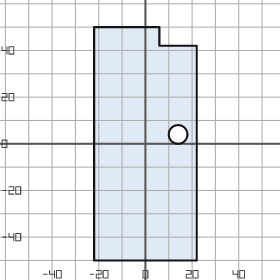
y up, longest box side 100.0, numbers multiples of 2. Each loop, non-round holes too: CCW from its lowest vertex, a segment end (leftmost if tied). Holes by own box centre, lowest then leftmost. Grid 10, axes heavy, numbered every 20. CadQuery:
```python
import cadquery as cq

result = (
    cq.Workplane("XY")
    .moveTo(-22.0, -50.0)
    .lineTo(22.0, -50.0)
    .lineTo(22.0, 42.0)
    .lineTo(6.0, 42.0)
    .lineTo(6.0, 50.0)
    .lineTo(-22.0, 50.0)
    .close()
    .moveTo(14.0, 4.0)
    .circle(4.0)
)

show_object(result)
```